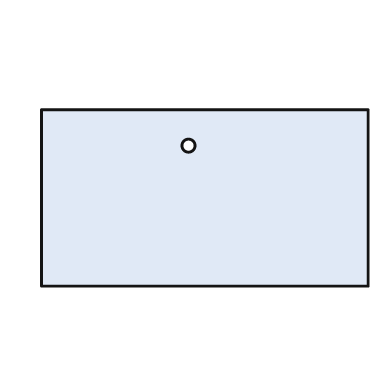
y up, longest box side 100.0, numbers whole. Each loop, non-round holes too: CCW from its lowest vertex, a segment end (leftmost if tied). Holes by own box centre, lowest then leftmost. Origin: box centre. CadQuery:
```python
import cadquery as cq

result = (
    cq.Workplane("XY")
    .moveTo(-50.0, -27.0)
    .lineTo(50.0, -27.0)
    .lineTo(50.0, 27.0)
    .lineTo(-50.0, 27.0)
    .close()
    .moveTo(-5.0, 16.0)
    .circle(2.0)
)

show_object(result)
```